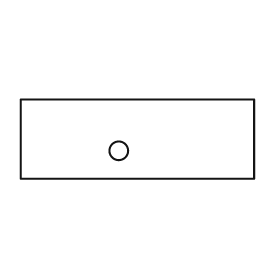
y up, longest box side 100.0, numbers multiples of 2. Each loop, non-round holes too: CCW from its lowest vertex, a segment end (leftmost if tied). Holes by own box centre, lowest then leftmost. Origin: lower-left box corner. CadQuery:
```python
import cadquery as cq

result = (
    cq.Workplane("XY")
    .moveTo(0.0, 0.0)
    .lineTo(100.0, 0.0)
    .lineTo(100.0, 34.0)
    .lineTo(0.0, 34.0)
    .close()
    .moveTo(42.0, 12.0)
    .circle(4.0)
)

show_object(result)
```